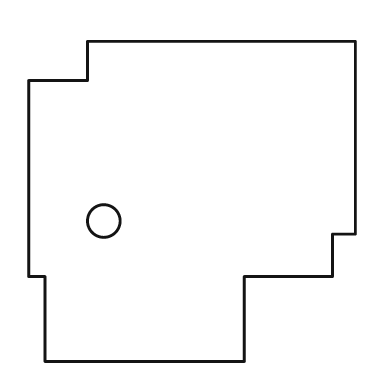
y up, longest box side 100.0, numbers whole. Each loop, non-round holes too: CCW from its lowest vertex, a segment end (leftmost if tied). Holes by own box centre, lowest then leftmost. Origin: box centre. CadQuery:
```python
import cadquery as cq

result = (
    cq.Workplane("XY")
    .moveTo(-45.0, -49.0)
    .lineTo(16.0, -49.0)
    .lineTo(16.0, -23.0)
    .lineTo(43.0, -23.0)
    .lineTo(43.0, -10.0)
    .lineTo(50.0, -10.0)
    .lineTo(50.0, 49.0)
    .lineTo(-32.0, 49.0)
    .lineTo(-32.0, 37.0)
    .lineTo(-50.0, 37.0)
    .lineTo(-50.0, -23.0)
    .lineTo(-45.0, -23.0)
    .close()
    .moveTo(-27.0, -6.0)
    .circle(5.0)
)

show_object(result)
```